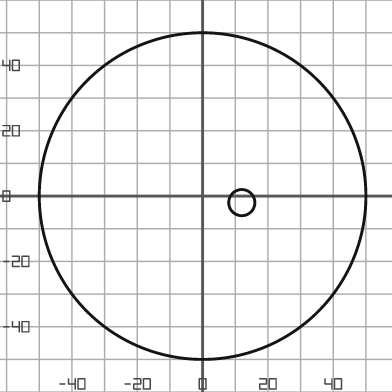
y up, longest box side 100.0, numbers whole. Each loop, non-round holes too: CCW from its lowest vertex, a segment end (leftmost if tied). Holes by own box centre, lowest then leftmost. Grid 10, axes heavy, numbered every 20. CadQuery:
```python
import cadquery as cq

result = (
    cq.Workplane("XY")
    .moveTo(0.0, 0.0)
    .circle(50.0)
    .moveTo(12.0, -2.0)
    .circle(4.0)
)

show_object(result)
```